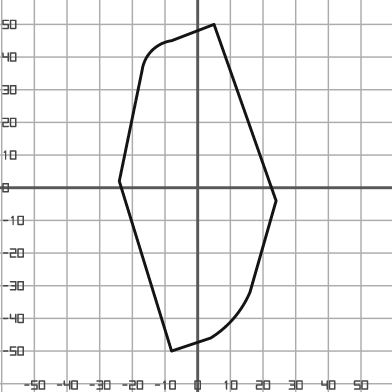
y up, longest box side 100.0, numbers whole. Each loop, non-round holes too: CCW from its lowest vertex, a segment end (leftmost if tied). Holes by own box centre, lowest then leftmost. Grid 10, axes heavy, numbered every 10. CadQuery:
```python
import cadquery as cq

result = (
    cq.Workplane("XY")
    .moveTo(-8.0, -50.0)
    .lineTo(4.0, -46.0)
    .threePointArc((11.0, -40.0), (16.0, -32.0))
    .lineTo(24.0, -4.0)
    .lineTo(5.0, 50.0)
    .lineTo(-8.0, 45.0)
    .threePointArc((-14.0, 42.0), (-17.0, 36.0))
    .lineTo(-24.0, 2.0)
    .close()
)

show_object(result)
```